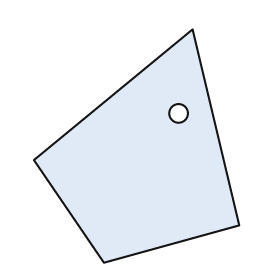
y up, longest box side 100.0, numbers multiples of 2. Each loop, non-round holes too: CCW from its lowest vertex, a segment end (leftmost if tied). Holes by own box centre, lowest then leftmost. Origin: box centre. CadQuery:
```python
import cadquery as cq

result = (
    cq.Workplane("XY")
    .moveTo(-14.0, -50.0)
    .lineTo(44.0, -34.0)
    .lineTo(24.0, 50.0)
    .lineTo(-44.0, -6.0)
    .close()
    .moveTo(18.0, 14.0)
    .circle(4.0)
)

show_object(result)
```